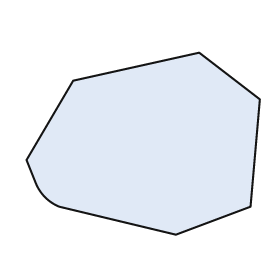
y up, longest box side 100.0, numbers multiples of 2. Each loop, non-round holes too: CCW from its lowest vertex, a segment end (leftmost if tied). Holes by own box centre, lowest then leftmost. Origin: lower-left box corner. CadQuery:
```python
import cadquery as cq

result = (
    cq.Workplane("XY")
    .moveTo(64.0, 0.0)
    .lineTo(96.0, 12.0)
    .lineTo(100.0, 58.0)
    .lineTo(74.0, 78.0)
    .lineTo(20.0, 66.0)
    .lineTo(0.0, 32.0)
    .lineTo(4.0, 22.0)
    .threePointArc((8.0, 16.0), (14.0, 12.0))
    .close()
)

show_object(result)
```